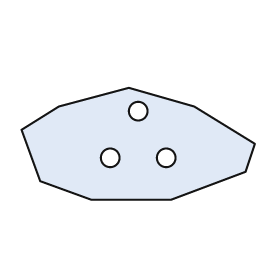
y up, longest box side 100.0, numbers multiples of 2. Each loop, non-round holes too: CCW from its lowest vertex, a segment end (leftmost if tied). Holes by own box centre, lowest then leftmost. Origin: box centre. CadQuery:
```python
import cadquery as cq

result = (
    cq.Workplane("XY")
    .moveTo(-20.0, -24.0)
    .lineTo(14.0, -24.0)
    .lineTo(46.0, -12.0)
    .lineTo(50.0, 0.0)
    .lineTo(24.0, 16.0)
    .lineTo(-4.0, 24.0)
    .lineTo(-34.0, 16.0)
    .lineTo(-50.0, 6.0)
    .lineTo(-42.0, -16.0)
    .close()
    .moveTo(-12.0, -6.0)
    .circle(4.0)
    .moveTo(12.0, -6.0)
    .circle(4.0)
    .moveTo(0.0, 14.0)
    .circle(4.0)
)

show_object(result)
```